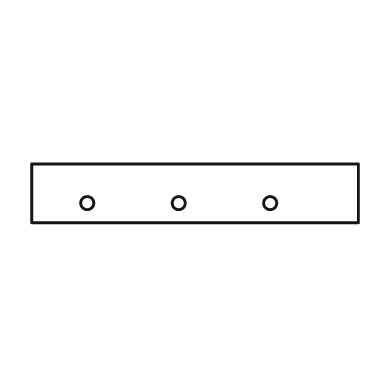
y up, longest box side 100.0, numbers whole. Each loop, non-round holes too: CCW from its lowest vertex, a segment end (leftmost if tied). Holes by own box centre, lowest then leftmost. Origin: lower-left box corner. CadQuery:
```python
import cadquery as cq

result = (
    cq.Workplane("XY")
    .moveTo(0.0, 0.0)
    .lineTo(100.0, 0.0)
    .lineTo(100.0, 18.0)
    .lineTo(0.0, 18.0)
    .close()
    .moveTo(17.0, 6.0)
    .circle(2.0)
    .moveTo(45.0, 6.0)
    .circle(2.0)
    .moveTo(73.0, 6.0)
    .circle(2.0)
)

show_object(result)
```